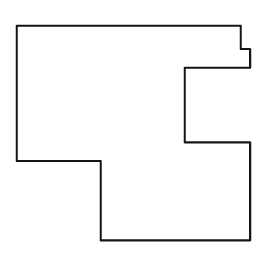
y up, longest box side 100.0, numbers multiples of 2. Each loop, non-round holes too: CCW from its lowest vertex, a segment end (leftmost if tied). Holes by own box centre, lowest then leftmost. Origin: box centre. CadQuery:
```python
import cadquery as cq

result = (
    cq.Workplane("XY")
    .moveTo(-14.0, -46.0)
    .lineTo(50.0, -46.0)
    .lineTo(50.0, -4.0)
    .lineTo(22.0, -4.0)
    .lineTo(22.0, 28.0)
    .lineTo(50.0, 28.0)
    .lineTo(50.0, 36.0)
    .lineTo(46.0, 36.0)
    .lineTo(46.0, 46.0)
    .lineTo(-50.0, 46.0)
    .lineTo(-50.0, -12.0)
    .lineTo(-14.0, -12.0)
    .close()
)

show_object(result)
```